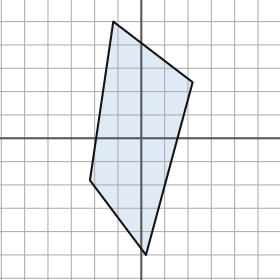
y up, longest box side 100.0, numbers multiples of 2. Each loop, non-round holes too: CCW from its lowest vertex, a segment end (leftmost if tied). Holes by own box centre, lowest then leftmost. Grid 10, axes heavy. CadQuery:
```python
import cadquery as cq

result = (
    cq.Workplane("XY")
    .moveTo(2.0, -50.0)
    .lineTo(22.0, 24.0)
    .lineTo(-12.0, 50.0)
    .lineTo(-22.0, -18.0)
    .close()
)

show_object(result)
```